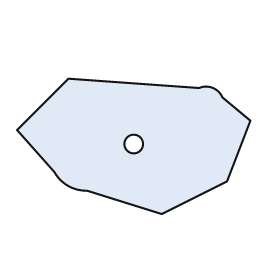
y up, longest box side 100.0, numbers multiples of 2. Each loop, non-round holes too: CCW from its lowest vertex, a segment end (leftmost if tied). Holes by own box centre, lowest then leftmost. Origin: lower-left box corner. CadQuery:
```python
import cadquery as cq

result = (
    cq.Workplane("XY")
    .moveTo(62.0, 0.0)
    .lineTo(90.0, 14.0)
    .lineTo(100.0, 40.0)
    .lineTo(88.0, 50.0)
    .threePointArc((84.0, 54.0), (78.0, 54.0))
    .lineTo(22.0, 58.0)
    .lineTo(0.0, 36.0)
    .lineTo(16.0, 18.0)
    .threePointArc((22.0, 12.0), (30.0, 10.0))
    .close()
    .moveTo(50.0, 30.0)
    .circle(4.0)
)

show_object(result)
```